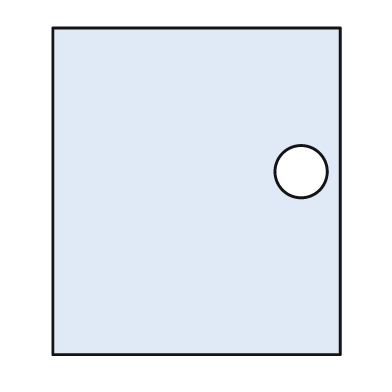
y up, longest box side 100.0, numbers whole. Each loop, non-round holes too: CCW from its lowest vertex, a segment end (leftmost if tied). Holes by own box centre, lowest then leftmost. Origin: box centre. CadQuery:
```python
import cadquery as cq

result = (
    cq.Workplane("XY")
    .moveTo(-44.0, -50.0)
    .lineTo(44.0, -50.0)
    .lineTo(44.0, 50.0)
    .lineTo(-44.0, 50.0)
    .close()
    .moveTo(32.0, 6.0)
    .circle(8.0)
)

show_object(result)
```